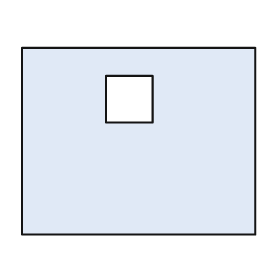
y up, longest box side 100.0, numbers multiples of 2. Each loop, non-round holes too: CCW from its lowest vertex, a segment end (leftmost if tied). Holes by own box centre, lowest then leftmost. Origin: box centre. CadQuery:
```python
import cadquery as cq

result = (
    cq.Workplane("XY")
    .moveTo(-50.0, -40.0)
    .lineTo(50.0, -40.0)
    .lineTo(50.0, 40.0)
    .lineTo(-50.0, 40.0)
    .close()
    .moveTo(-14.0, 8.0)
    .lineTo(6.0, 8.0)
    .lineTo(6.0, 28.0)
    .lineTo(-14.0, 28.0)
    .close()
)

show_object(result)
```